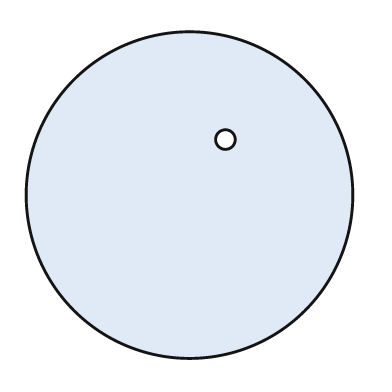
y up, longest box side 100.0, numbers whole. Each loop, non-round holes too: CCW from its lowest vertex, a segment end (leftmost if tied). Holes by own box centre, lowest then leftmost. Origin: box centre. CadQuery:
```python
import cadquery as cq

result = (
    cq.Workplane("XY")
    .moveTo(0.0, 0.0)
    .circle(50.0)
    .moveTo(11.0, 17.0)
    .circle(3.0)
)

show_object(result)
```